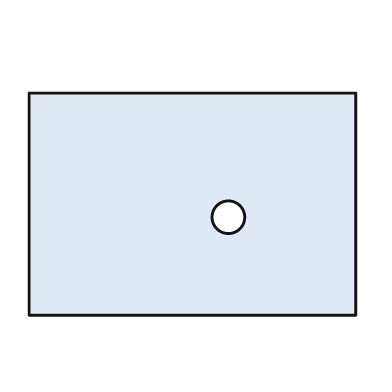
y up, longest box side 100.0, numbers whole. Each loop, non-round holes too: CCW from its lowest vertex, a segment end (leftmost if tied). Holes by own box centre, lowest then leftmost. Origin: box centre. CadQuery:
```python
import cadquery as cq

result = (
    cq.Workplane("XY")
    .moveTo(-50.0, -34.0)
    .lineTo(50.0, -34.0)
    .lineTo(50.0, 34.0)
    .lineTo(-50.0, 34.0)
    .close()
    .moveTo(11.0, -4.0)
    .circle(5.0)
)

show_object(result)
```